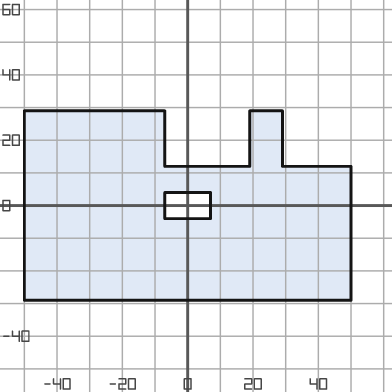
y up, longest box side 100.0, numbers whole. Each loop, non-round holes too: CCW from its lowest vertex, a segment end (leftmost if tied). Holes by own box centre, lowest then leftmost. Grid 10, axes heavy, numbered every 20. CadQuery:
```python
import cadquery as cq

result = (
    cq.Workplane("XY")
    .moveTo(-50.0, -29.0)
    .lineTo(50.0, -29.0)
    .lineTo(50.0, 12.0)
    .lineTo(29.0, 12.0)
    .lineTo(29.0, 29.0)
    .lineTo(19.0, 29.0)
    .lineTo(19.0, 12.0)
    .lineTo(-7.0, 12.0)
    .lineTo(-7.0, 29.0)
    .lineTo(-50.0, 29.0)
    .close()
    .moveTo(-7.0, -4.0)
    .lineTo(7.0, -4.0)
    .lineTo(7.0, 4.0)
    .lineTo(-7.0, 4.0)
    .close()
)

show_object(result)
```